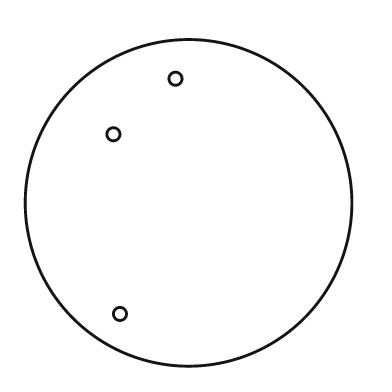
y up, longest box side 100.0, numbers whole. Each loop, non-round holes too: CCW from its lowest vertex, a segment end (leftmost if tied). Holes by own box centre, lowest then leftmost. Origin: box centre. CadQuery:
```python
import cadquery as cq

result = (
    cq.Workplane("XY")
    .moveTo(0.0, 0.0)
    .circle(50.0)
    .moveTo(-21.0, -34.0)
    .circle(2.0)
    .moveTo(-23.0, 21.0)
    .circle(2.0)
    .moveTo(-4.0, 38.0)
    .circle(2.0)
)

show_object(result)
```